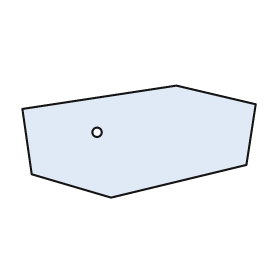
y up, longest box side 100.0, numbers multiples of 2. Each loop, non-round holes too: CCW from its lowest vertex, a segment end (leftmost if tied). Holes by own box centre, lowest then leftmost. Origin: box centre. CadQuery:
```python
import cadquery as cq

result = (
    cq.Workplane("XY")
    .moveTo(-12.0, -24.0)
    .lineTo(46.0, -10.0)
    .lineTo(50.0, 16.0)
    .lineTo(16.0, 24.0)
    .lineTo(-50.0, 14.0)
    .lineTo(-46.0, -14.0)
    .close()
    .moveTo(-18.0, 4.0)
    .circle(2.0)
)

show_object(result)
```